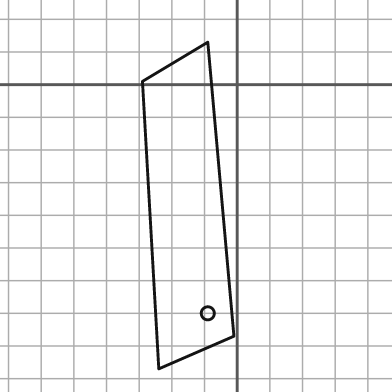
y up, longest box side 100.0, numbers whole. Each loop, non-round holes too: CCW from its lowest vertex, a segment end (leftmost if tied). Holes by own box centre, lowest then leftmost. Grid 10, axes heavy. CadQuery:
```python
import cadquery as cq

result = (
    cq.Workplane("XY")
    .moveTo(-24.0, -87.0)
    .lineTo(-1.0, -77.0)
    .lineTo(-9.0, 13.0)
    .lineTo(-29.0, 1.0)
    .close()
    .moveTo(-9.0, -70.0)
    .circle(2.0)
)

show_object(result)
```